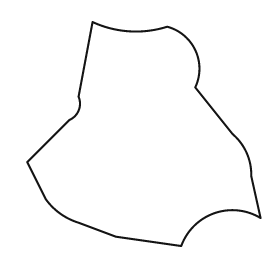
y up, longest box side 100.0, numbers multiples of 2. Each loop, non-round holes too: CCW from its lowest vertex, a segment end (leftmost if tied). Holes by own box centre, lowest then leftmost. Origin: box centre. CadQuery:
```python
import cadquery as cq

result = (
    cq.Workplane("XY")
    .moveTo(16.0, -48.0)
    .threePointArc((30.0, -34.0), (50.0, -36.0))
    .lineTo(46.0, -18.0)
    .threePointArc((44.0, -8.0), (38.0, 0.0))
    .lineTo(22.0, 20.0)
    .threePointArc((22.0, 36.0), (10.0, 46.0))
    .threePointArc((-6.0, 44.0), (-22.0, 48.0))
    .lineTo(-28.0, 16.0)
    .threePointArc((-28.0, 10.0), (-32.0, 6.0))
    .lineTo(-50.0, -12.0)
    .lineTo(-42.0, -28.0)
    .threePointArc((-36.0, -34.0), (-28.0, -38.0))
    .lineTo(-12.0, -44.0)
    .close()
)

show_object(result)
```